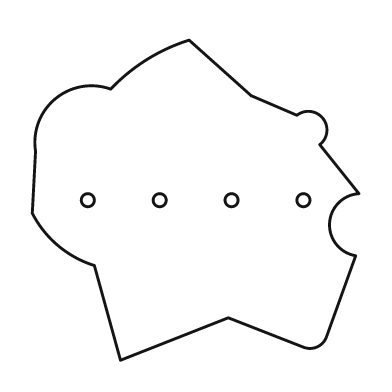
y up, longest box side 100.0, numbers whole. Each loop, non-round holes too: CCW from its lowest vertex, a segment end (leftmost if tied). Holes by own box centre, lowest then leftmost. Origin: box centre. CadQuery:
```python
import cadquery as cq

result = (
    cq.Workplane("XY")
    .moveTo(-23.0, -49.0)
    .lineTo(10.0, -36.0)
    .lineTo(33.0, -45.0)
    .threePointArc((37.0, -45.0), (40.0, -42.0))
    .lineTo(49.0, -17.0)
    .threePointArc((41.0, -7.0), (50.0, 2.0))
    .lineTo(38.0, 17.0)
    .threePointArc((39.0, 25.0), (31.0, 26.0))
    .lineTo(17.0, 32.0)
    .lineTo(-2.0, 49.0)
    .threePointArc((-15.0, 43.0), (-26.0, 34.0))
    .threePointArc((-43.0, 31.0), (-49.0, 15.0))
    .lineTo(-50.0, -4.0)
    .threePointArc((-42.0, -14.0), (-31.0, -20.0))
    .close()
    .moveTo(-33.0, 0.0)
    .circle(2.0)
    .moveTo(-11.0, 0.0)
    .circle(2.0)
    .moveTo(11.0, 0.0)
    .circle(2.0)
    .moveTo(33.0, 0.0)
    .circle(2.0)
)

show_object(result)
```